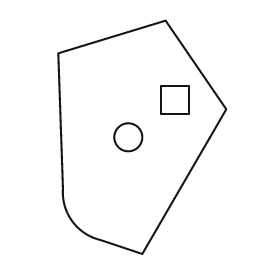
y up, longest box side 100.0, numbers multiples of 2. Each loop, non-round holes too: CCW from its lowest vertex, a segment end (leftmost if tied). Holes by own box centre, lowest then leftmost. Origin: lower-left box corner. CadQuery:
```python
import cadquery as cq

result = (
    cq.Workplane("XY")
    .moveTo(36.0, 0.0)
    .lineTo(72.0, 62.0)
    .lineTo(46.0, 100.0)
    .lineTo(0.0, 86.0)
    .lineTo(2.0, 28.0)
    .threePointArc((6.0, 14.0), (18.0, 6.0))
    .close()
    .moveTo(30.0, 50.0)
    .circle(6.0)
    .moveTo(44.0, 60.0)
    .lineTo(56.0, 60.0)
    .lineTo(56.0, 72.0)
    .lineTo(44.0, 72.0)
    .close()
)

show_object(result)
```